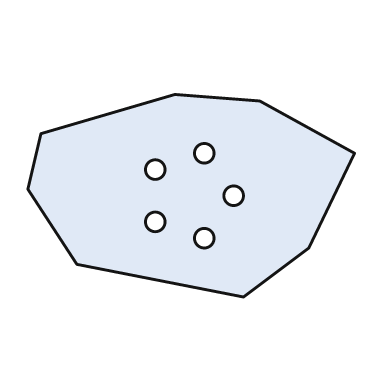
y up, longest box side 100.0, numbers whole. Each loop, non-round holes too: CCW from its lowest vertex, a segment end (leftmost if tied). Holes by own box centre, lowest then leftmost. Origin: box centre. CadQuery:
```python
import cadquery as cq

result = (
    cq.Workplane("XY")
    .moveTo(16.0, -31.0)
    .lineTo(36.0, -16.0)
    .lineTo(50.0, 13.0)
    .lineTo(21.0, 29.0)
    .lineTo(-5.0, 31.0)
    .lineTo(-46.0, 19.0)
    .lineTo(-50.0, 2.0)
    .lineTo(-35.0, -21.0)
    .close()
    .moveTo(4.0, -13.0)
    .circle(3.0)
    .moveTo(-11.0, -8.0)
    .circle(3.0)
    .moveTo(13.0, 0.0)
    .circle(3.0)
    .moveTo(-11.0, 8.0)
    .circle(3.0)
    .moveTo(4.0, 13.0)
    .circle(3.0)
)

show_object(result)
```